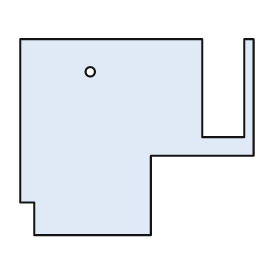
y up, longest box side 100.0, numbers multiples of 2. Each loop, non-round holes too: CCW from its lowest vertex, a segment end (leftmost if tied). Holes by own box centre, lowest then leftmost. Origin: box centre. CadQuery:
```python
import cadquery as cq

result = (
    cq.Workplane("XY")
    .moveTo(-44.0, -42.0)
    .lineTo(6.0, -42.0)
    .lineTo(6.0, -8.0)
    .lineTo(50.0, -8.0)
    .lineTo(50.0, 42.0)
    .lineTo(46.0, 42.0)
    .lineTo(46.0, 0.0)
    .lineTo(28.0, 0.0)
    .lineTo(28.0, 42.0)
    .lineTo(-50.0, 42.0)
    .lineTo(-50.0, -28.0)
    .lineTo(-44.0, -28.0)
    .close()
    .moveTo(-20.0, 28.0)
    .circle(2.0)
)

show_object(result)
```